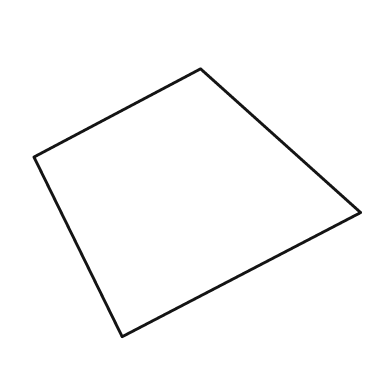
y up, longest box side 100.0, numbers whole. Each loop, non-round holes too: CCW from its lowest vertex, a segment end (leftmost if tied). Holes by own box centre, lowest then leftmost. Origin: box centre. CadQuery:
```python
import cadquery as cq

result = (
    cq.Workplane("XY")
    .moveTo(-23.0, -41.0)
    .lineTo(50.0, -3.0)
    .lineTo(1.0, 41.0)
    .lineTo(-50.0, 14.0)
    .close()
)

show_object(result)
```